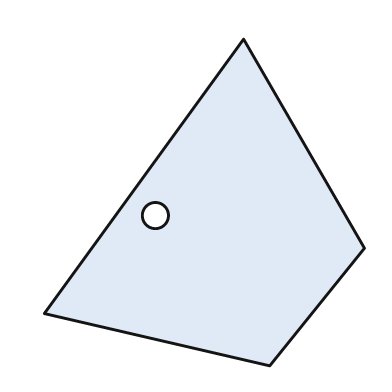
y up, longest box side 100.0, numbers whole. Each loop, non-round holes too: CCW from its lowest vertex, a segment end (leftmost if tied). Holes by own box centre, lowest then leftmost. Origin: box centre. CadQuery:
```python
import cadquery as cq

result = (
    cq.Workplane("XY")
    .moveTo(20.0, -50.0)
    .lineTo(49.0, -14.0)
    .lineTo(12.0, 50.0)
    .lineTo(-49.0, -34.0)
    .close()
    .moveTo(-15.0, -4.0)
    .circle(4.0)
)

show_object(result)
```